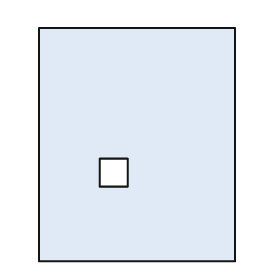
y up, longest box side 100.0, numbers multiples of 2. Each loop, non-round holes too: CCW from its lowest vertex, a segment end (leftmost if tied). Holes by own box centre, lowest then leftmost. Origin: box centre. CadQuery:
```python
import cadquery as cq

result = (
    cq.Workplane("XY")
    .moveTo(-42.0, -50.0)
    .lineTo(42.0, -50.0)
    .lineTo(42.0, 50.0)
    .lineTo(-42.0, 50.0)
    .close()
    .moveTo(-16.0, -18.0)
    .lineTo(-4.0, -18.0)
    .lineTo(-4.0, -6.0)
    .lineTo(-16.0, -6.0)
    .close()
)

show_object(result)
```